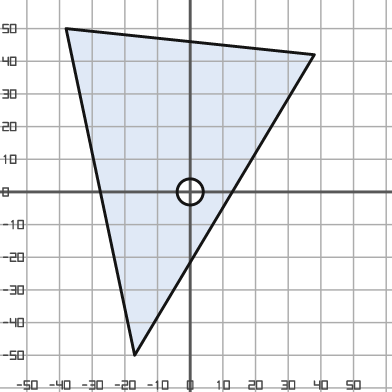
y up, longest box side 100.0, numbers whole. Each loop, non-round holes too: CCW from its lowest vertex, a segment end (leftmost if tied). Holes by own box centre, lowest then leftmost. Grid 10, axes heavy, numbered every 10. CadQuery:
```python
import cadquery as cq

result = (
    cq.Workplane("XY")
    .moveTo(-17.0, -50.0)
    .lineTo(38.0, 42.0)
    .lineTo(-38.0, 50.0)
    .close()
    .moveTo(0.0, 0.0)
    .circle(4.0)
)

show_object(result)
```